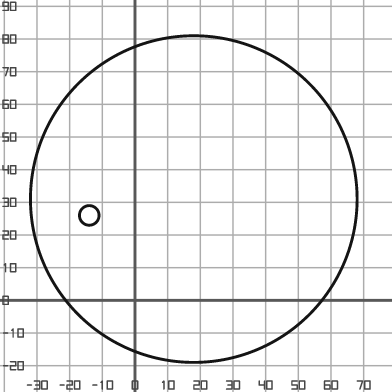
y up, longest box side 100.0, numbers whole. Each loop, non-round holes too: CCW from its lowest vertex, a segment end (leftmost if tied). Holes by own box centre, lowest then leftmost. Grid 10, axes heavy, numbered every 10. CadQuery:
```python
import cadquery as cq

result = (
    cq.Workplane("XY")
    .moveTo(18.0, 31.0)
    .circle(50.0)
    .moveTo(-14.0, 26.0)
    .circle(3.0)
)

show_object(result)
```